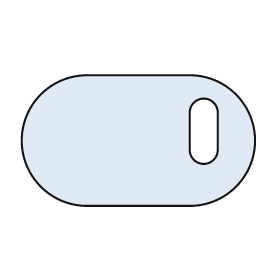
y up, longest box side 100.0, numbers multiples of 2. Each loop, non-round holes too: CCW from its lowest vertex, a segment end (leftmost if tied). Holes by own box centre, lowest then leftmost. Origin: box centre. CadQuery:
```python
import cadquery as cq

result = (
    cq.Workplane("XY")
    .moveTo(-22.0, -28.0)
    .lineTo(22.0, -28.0)
    .threePointArc((50.0, 0.0), (22.0, 28.0))
    .lineTo(-22.0, 28.0)
    .threePointArc((-50.0, 0.0), (-22.0, -28.0))
    .close()
    .moveTo(22.0, -4.0)
    .threePointArc((28.0, -10.0), (34.0, -4.0))
    .lineTo(34.0, 12.0)
    .threePointArc((28.0, 18.0), (22.0, 12.0))
    .close()
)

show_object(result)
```